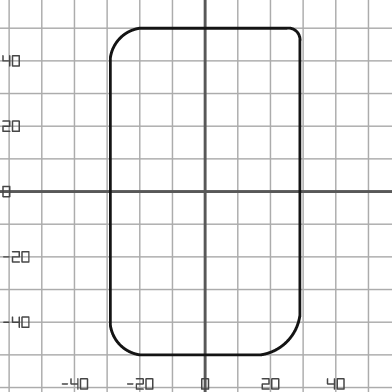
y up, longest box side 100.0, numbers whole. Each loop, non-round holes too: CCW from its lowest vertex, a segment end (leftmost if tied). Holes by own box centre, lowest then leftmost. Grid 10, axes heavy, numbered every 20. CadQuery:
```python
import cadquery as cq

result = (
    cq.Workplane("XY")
    .moveTo(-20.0, -50.0)
    .lineTo(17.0, -50.0)
    .threePointArc((25.0, -46.0), (29.0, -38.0))
    .lineTo(29.0, 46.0)
    .threePointArc((28.0, 49.0), (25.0, 50.0))
    .lineTo(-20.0, 50.0)
    .threePointArc((-26.0, 47.0), (-29.0, 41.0))
    .lineTo(-29.0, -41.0)
    .threePointArc((-26.0, -47.0), (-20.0, -50.0))
    .close()
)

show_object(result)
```